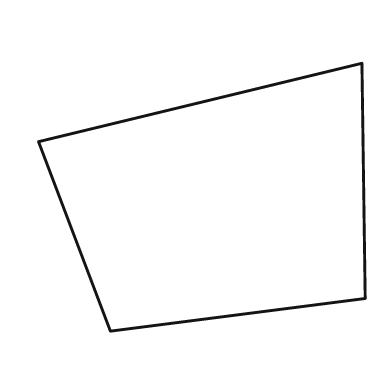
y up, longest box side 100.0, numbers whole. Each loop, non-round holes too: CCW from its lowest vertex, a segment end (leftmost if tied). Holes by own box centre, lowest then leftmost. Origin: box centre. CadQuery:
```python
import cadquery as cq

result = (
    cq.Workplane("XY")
    .moveTo(-28.0, -41.0)
    .lineTo(50.0, -31.0)
    .lineTo(49.0, 41.0)
    .lineTo(-50.0, 17.0)
    .close()
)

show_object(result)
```